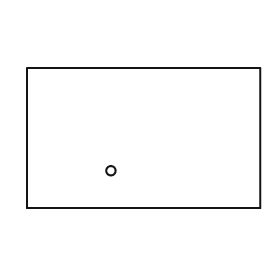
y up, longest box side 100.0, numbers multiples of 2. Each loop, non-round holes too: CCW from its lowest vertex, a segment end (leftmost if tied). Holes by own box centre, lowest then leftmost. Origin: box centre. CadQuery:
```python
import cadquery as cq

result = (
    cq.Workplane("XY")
    .moveTo(-50.0, -30.0)
    .lineTo(50.0, -30.0)
    .lineTo(50.0, 30.0)
    .lineTo(-50.0, 30.0)
    .close()
    .moveTo(-14.0, -14.0)
    .circle(2.0)
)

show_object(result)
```